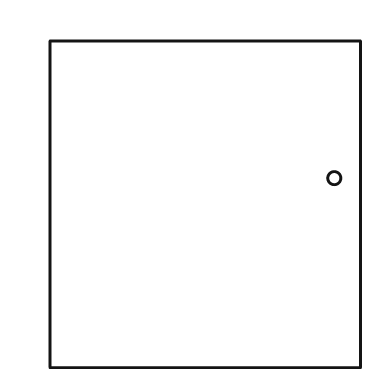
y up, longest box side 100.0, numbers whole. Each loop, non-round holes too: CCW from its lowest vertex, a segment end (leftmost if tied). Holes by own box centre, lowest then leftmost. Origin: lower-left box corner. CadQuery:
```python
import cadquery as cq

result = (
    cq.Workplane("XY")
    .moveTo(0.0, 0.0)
    .lineTo(95.0, 0.0)
    .lineTo(95.0, 100.0)
    .lineTo(0.0, 100.0)
    .close()
    .moveTo(87.0, 58.0)
    .circle(2.0)
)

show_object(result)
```